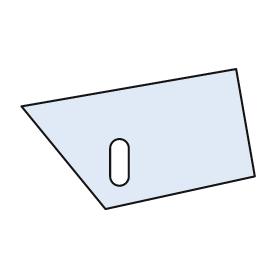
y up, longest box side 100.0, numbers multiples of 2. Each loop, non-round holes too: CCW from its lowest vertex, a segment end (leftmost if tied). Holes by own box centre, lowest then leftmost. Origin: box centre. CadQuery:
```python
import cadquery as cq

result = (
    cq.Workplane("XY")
    .moveTo(-14.0, -30.0)
    .lineTo(50.0, -16.0)
    .lineTo(42.0, 30.0)
    .lineTo(-50.0, 14.0)
    .close()
    .moveTo(-12.0, -16.0)
    .threePointArc((-8.0, -20.0), (-4.0, -16.0))
    .lineTo(-4.0, -4.0)
    .threePointArc((-8.0, 0.0), (-12.0, -4.0))
    .close()
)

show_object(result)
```